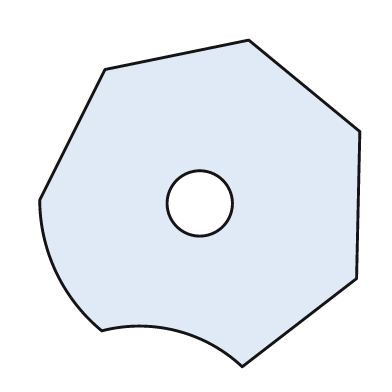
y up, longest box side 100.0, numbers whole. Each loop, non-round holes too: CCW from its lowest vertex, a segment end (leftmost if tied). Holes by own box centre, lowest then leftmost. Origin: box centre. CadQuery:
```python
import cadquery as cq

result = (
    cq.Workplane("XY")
    .moveTo(13.0, -50.0)
    .lineTo(48.0, -23.0)
    .lineTo(49.0, 22.0)
    .lineTo(15.0, 50.0)
    .lineTo(-29.0, 41.0)
    .lineTo(-49.0, 1.0)
    .threePointArc((-44.0, -21.0), (-30.0, -39.0))
    .threePointArc((-7.0, -39.0), (13.0, -50.0))
    .close()
    .moveTo(0.0, 0.0)
    .circle(10.0)
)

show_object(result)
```